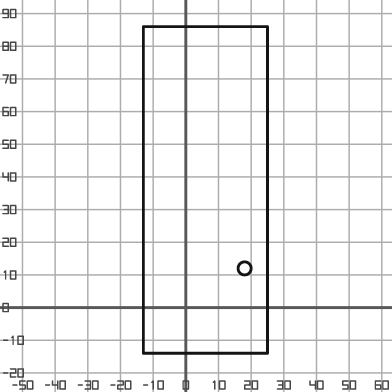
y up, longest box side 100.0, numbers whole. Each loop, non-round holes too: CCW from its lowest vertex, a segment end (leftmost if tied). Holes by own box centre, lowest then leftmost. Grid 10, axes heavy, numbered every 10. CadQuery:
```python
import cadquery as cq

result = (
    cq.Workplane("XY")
    .moveTo(-13.0, -14.0)
    .lineTo(25.0, -14.0)
    .lineTo(25.0, 86.0)
    .lineTo(-13.0, 86.0)
    .close()
    .moveTo(18.0, 12.0)
    .circle(2.0)
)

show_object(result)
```